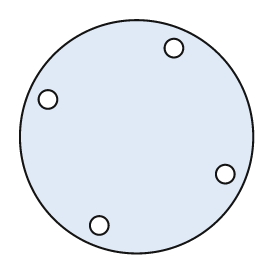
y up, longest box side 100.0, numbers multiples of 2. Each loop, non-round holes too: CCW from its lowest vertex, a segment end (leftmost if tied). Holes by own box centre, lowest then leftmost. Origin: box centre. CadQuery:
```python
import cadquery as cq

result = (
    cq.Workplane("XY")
    .moveTo(0.0, 0.0)
    .circle(50.0)
    .moveTo(-16.0, -38.0)
    .circle(4.0)
    .moveTo(38.0, -16.0)
    .circle(4.0)
    .moveTo(-38.0, 16.0)
    .circle(4.0)
    .moveTo(16.0, 38.0)
    .circle(4.0)
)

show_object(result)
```